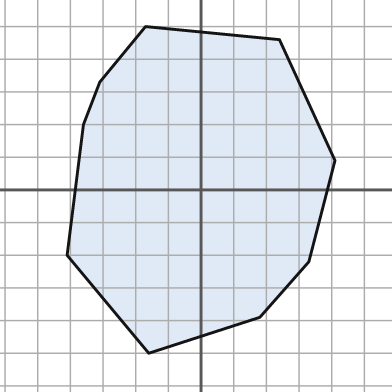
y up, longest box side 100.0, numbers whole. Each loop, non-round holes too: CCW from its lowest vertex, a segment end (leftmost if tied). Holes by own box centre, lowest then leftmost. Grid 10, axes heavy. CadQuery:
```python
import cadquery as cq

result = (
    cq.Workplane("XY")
    .moveTo(-16.0, -50.0)
    .lineTo(18.0, -39.0)
    .lineTo(33.0, -22.0)
    .lineTo(41.0, 9.0)
    .lineTo(24.0, 46.0)
    .lineTo(-17.0, 50.0)
    .lineTo(-31.0, 33.0)
    .lineTo(-36.0, 20.0)
    .lineTo(-41.0, -20.0)
    .close()
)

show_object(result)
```